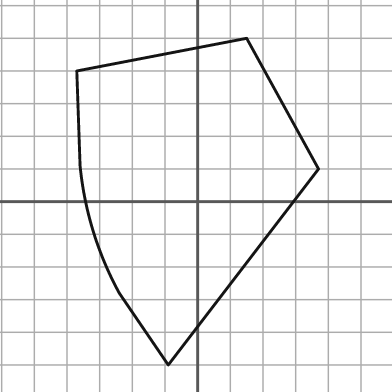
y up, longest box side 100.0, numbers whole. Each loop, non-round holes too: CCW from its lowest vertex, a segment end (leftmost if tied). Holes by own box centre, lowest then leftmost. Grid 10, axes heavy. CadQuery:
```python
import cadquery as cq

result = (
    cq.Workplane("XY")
    .moveTo(-9.0, -50.0)
    .lineTo(37.0, 10.0)
    .lineTo(15.0, 50.0)
    .lineTo(-37.0, 40.0)
    .lineTo(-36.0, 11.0)
    .threePointArc((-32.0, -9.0), (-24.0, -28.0))
    .close()
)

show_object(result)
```